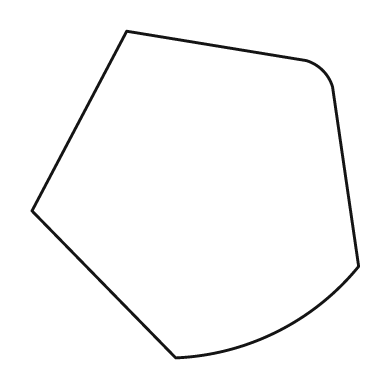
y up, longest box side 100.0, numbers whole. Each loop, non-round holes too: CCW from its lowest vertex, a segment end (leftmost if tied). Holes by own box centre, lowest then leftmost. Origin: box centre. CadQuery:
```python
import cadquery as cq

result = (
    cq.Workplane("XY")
    .moveTo(-6.0, -50.0)
    .threePointArc((25.0, -42.0), (50.0, -22.0))
    .lineTo(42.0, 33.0)
    .threePointArc((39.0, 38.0), (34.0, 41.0))
    .lineTo(-21.0, 50.0)
    .lineTo(-50.0, -5.0)
    .close()
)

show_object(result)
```